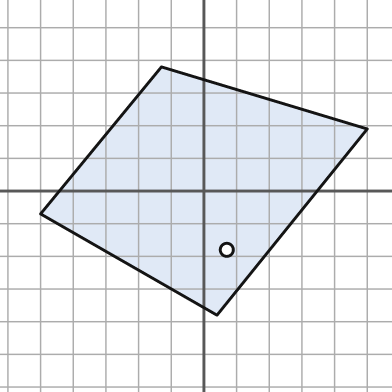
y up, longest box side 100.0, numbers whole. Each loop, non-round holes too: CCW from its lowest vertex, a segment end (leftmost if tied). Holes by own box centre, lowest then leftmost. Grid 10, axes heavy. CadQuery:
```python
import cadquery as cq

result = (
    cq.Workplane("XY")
    .moveTo(4.0, -38.0)
    .lineTo(50.0, 19.0)
    .lineTo(-13.0, 38.0)
    .lineTo(-50.0, -7.0)
    .close()
    .moveTo(7.0, -18.0)
    .circle(2.0)
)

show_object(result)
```